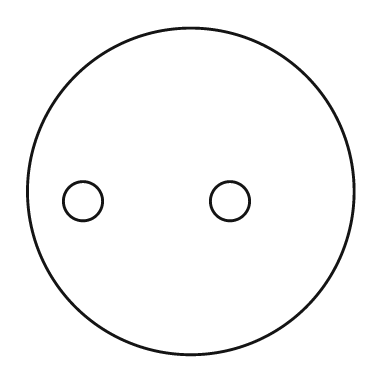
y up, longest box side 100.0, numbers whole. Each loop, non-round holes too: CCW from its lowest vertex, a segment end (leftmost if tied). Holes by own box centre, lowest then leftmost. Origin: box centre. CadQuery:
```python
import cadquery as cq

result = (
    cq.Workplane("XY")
    .moveTo(0.0, 0.0)
    .circle(50.0)
    .moveTo(-33.0, -3.0)
    .circle(6.0)
    .moveTo(12.0, -3.0)
    .circle(6.0)
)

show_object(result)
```